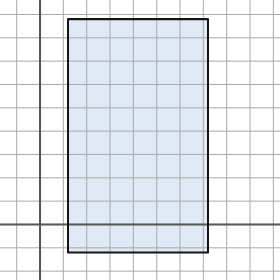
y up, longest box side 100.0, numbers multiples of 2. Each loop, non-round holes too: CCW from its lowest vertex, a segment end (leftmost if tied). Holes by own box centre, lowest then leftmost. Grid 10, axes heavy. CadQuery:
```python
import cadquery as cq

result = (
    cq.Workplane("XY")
    .moveTo(12.0, -12.0)
    .lineTo(72.0, -12.0)
    .lineTo(72.0, 88.0)
    .lineTo(12.0, 88.0)
    .close()
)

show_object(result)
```